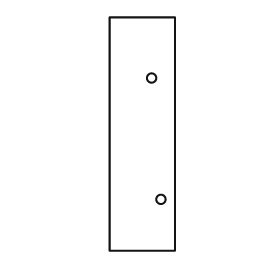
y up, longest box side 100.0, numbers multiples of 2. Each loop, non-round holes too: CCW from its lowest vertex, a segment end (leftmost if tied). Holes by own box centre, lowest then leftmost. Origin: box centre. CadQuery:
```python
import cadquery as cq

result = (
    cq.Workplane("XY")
    .moveTo(-14.0, -50.0)
    .lineTo(14.0, -50.0)
    .lineTo(14.0, 50.0)
    .lineTo(-14.0, 50.0)
    .close()
    .moveTo(8.0, -28.0)
    .circle(2.0)
    .moveTo(4.0, 24.0)
    .circle(2.0)
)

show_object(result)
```